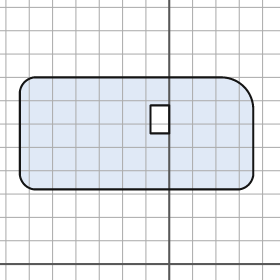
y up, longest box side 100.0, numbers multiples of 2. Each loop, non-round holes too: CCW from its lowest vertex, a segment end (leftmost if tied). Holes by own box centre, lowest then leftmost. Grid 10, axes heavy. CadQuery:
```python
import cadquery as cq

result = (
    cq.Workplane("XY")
    .moveTo(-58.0, 32.0)
    .lineTo(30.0, 32.0)
    .threePointArc((34.0, 34.0), (36.0, 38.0))
    .lineTo(36.0, 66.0)
    .threePointArc((32.0, 76.0), (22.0, 80.0))
    .lineTo(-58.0, 80.0)
    .threePointArc((-62.0, 78.0), (-64.0, 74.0))
    .lineTo(-64.0, 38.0)
    .threePointArc((-62.0, 34.0), (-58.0, 32.0))
    .close()
    .moveTo(-8.0, 56.0)
    .lineTo(0.0, 56.0)
    .lineTo(0.0, 68.0)
    .lineTo(-8.0, 68.0)
    .close()
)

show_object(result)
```